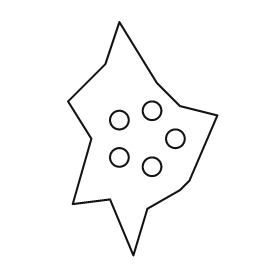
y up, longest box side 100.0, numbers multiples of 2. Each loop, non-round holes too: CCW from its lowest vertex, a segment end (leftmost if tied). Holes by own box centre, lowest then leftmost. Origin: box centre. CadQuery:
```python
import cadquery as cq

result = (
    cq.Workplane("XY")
    .moveTo(-4.0, -50.0)
    .lineTo(2.0, -30.0)
    .lineTo(16.0, -22.0)
    .lineTo(20.0, -18.0)
    .lineTo(32.0, 10.0)
    .lineTo(16.0, 14.0)
    .lineTo(6.0, 24.0)
    .lineTo(-10.0, 50.0)
    .lineTo(-16.0, 32.0)
    .lineTo(-32.0, 16.0)
    .lineTo(-22.0, 0.0)
    .lineTo(-30.0, -28.0)
    .lineTo(-14.0, -26.0)
    .close()
    .moveTo(4.0, -12.0)
    .circle(4.0)
    .moveTo(-10.0, -8.0)
    .circle(4.0)
    .moveTo(14.0, 0.0)
    .circle(4.0)
    .moveTo(-10.0, 8.0)
    .circle(4.0)
    .moveTo(4.0, 12.0)
    .circle(4.0)
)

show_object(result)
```